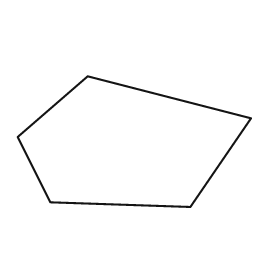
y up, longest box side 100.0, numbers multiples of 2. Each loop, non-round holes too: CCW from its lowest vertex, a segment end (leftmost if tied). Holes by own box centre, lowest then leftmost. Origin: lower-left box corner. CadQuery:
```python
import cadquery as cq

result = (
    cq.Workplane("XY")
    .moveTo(74.0, 0.0)
    .lineTo(100.0, 38.0)
    .lineTo(30.0, 56.0)
    .lineTo(0.0, 30.0)
    .lineTo(14.0, 2.0)
    .close()
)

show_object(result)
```